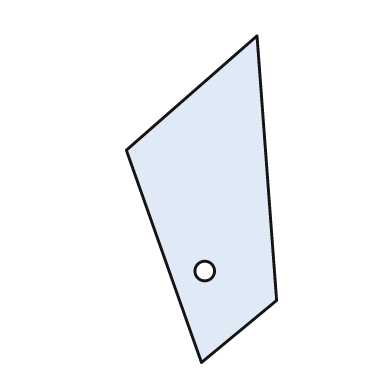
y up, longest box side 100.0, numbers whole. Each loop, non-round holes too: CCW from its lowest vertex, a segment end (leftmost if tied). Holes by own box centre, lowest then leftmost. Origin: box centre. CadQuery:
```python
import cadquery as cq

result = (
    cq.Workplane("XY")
    .moveTo(0.0, -50.0)
    .lineTo(23.0, -31.0)
    .lineTo(17.0, 50.0)
    .lineTo(-23.0, 15.0)
    .close()
    .moveTo(1.0, -22.0)
    .circle(3.0)
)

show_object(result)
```